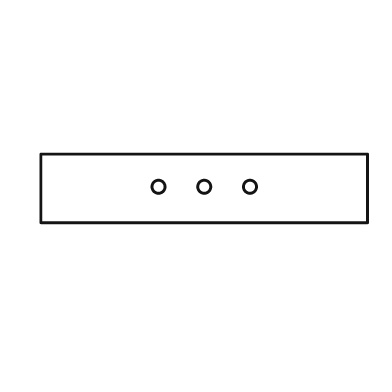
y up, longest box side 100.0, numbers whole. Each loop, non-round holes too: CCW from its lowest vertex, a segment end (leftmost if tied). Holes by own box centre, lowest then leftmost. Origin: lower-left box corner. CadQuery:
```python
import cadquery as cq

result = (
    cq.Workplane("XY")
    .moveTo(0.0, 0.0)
    .lineTo(100.0, 0.0)
    .lineTo(100.0, 21.0)
    .lineTo(0.0, 21.0)
    .close()
    .moveTo(36.0, 11.0)
    .circle(2.0)
    .moveTo(50.0, 11.0)
    .circle(2.0)
    .moveTo(64.0, 11.0)
    .circle(2.0)
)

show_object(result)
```